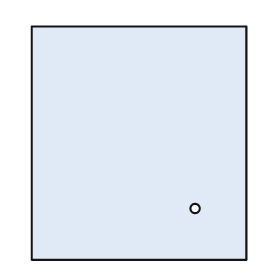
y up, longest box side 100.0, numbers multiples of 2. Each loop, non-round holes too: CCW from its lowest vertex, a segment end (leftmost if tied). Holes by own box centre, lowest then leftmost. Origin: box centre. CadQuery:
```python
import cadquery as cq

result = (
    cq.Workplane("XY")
    .moveTo(-46.0, -50.0)
    .lineTo(46.0, -50.0)
    .lineTo(46.0, 50.0)
    .lineTo(-46.0, 50.0)
    .close()
    .moveTo(24.0, -28.0)
    .circle(2.0)
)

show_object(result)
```